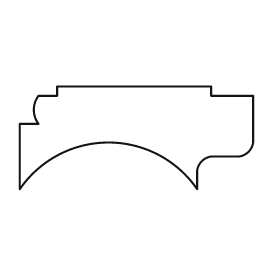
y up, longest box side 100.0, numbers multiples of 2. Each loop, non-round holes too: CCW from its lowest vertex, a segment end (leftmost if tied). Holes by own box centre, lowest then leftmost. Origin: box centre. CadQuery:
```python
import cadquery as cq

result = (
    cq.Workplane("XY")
    .moveTo(-50.0, -22.0)
    .threePointArc((-12.0, -2.0), (26.0, -22.0))
    .lineTo(26.0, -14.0)
    .threePointArc((28.0, -10.0), (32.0, -8.0))
    .lineTo(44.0, -8.0)
    .threePointArc((48.0, -6.0), (50.0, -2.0))
    .lineTo(50.0, 18.0)
    .lineTo(32.0, 18.0)
    .lineTo(32.0, 22.0)
    .lineTo(-34.0, 22.0)
    .lineTo(-34.0, 18.0)
    .lineTo(-42.0, 18.0)
    .threePointArc((-44.0, 12.0), (-42.0, 6.0))
    .lineTo(-50.0, 6.0)
    .close()
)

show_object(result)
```